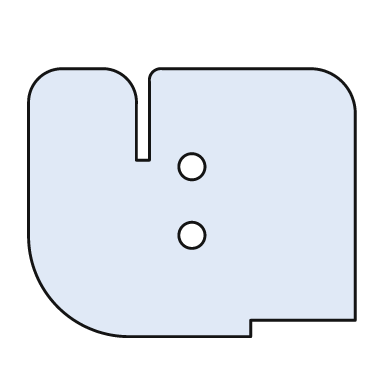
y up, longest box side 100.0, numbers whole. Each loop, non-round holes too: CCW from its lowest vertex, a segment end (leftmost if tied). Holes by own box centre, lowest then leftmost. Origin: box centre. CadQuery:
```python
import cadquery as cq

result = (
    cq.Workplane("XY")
    .moveTo(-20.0, -41.0)
    .lineTo(18.0, -41.0)
    .lineTo(18.0, -36.0)
    .lineTo(50.0, -36.0)
    .lineTo(50.0, 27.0)
    .threePointArc((46.0, 37.0), (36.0, 41.0))
    .lineTo(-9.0, 41.0)
    .threePointArc((-12.0, 40.0), (-13.0, 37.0))
    .lineTo(-13.0, 13.0)
    .lineTo(-17.0, 13.0)
    .lineTo(-17.0, 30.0)
    .threePointArc((-20.0, 38.0), (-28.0, 41.0))
    .lineTo(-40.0, 41.0)
    .threePointArc((-47.0, 38.0), (-50.0, 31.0))
    .lineTo(-50.0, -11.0)
    .threePointArc((-41.0, -32.0), (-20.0, -41.0))
    .close()
    .moveTo(0.0, -10.0)
    .circle(4.0)
    .moveTo(0.0, 11.0)
    .circle(4.0)
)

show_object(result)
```